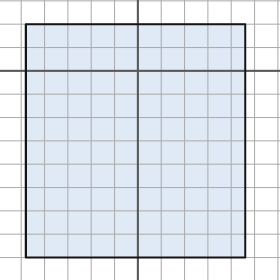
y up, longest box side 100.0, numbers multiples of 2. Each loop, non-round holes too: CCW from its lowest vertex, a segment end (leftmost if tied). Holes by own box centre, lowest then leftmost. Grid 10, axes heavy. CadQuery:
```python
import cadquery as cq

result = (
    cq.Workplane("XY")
    .moveTo(-48.0, -80.0)
    .lineTo(46.0, -80.0)
    .lineTo(46.0, 20.0)
    .lineTo(-48.0, 20.0)
    .close()
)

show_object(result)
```